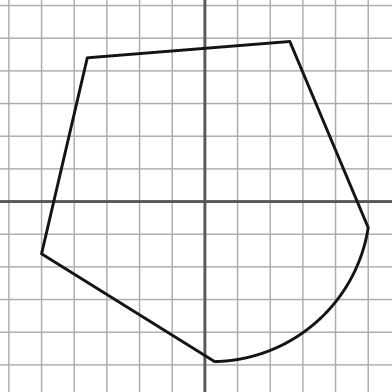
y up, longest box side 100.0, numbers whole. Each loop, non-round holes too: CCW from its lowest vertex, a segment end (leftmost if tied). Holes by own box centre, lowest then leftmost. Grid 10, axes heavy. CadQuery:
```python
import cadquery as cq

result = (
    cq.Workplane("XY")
    .moveTo(3.0, -49.0)
    .threePointArc((34.0, -37.0), (50.0, -8.0))
    .lineTo(26.0, 49.0)
    .lineTo(-36.0, 44.0)
    .lineTo(-50.0, -16.0)
    .close()
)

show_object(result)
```